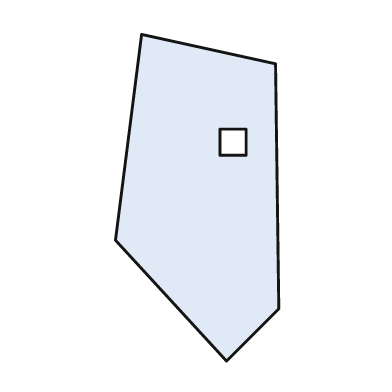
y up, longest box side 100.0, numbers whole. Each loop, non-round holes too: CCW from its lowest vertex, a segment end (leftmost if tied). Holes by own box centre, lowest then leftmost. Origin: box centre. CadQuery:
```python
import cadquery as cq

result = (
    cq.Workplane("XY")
    .moveTo(9.0, -50.0)
    .lineTo(25.0, -34.0)
    .lineTo(24.0, 41.0)
    .lineTo(-17.0, 50.0)
    .lineTo(-25.0, -13.0)
    .close()
    .moveTo(7.0, 13.0)
    .lineTo(15.0, 13.0)
    .lineTo(15.0, 21.0)
    .lineTo(7.0, 21.0)
    .close()
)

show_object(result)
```